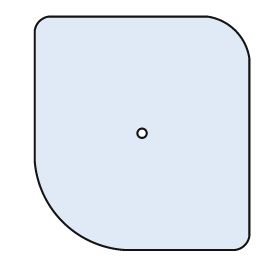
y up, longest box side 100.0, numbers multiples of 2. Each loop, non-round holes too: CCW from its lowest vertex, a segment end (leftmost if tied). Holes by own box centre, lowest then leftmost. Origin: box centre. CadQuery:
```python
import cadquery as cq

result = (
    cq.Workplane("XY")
    .moveTo(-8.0, -50.0)
    .lineTo(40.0, -50.0)
    .threePointArc((44.0, -48.0), (46.0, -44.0))
    .lineTo(46.0, 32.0)
    .threePointArc((40.0, 44.0), (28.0, 50.0))
    .lineTo(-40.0, 50.0)
    .threePointArc((-44.0, 48.0), (-46.0, 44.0))
    .lineTo(-46.0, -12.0)
    .threePointArc((-34.0, -38.0), (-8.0, -50.0))
    .close()
    .moveTo(0.0, 0.0)
    .circle(2.0)
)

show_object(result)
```